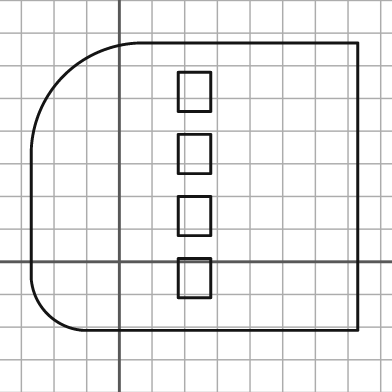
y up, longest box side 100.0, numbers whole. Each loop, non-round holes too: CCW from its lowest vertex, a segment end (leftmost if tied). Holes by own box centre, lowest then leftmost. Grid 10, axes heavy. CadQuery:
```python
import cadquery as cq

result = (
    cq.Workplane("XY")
    .moveTo(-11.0, -21.0)
    .lineTo(73.0, -21.0)
    .lineTo(73.0, 67.0)
    .lineTo(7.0, 67.0)
    .threePointArc((-17.0, 57.0), (-27.0, 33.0))
    .lineTo(-27.0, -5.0)
    .threePointArc((-22.0, -16.0), (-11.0, -21.0))
    .close()
    .moveTo(18.0, -11.0)
    .lineTo(28.0, -11.0)
    .lineTo(28.0, 1.0)
    .lineTo(18.0, 1.0)
    .close()
    .moveTo(18.0, 8.0)
    .lineTo(28.0, 8.0)
    .lineTo(28.0, 20.0)
    .lineTo(18.0, 20.0)
    .close()
    .moveTo(18.0, 27.0)
    .lineTo(28.0, 27.0)
    .lineTo(28.0, 39.0)
    .lineTo(18.0, 39.0)
    .close()
    .moveTo(18.0, 46.0)
    .lineTo(28.0, 46.0)
    .lineTo(28.0, 58.0)
    .lineTo(18.0, 58.0)
    .close()
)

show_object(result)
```